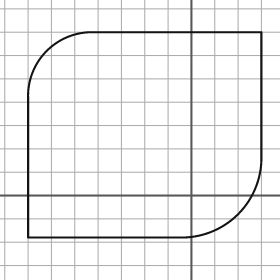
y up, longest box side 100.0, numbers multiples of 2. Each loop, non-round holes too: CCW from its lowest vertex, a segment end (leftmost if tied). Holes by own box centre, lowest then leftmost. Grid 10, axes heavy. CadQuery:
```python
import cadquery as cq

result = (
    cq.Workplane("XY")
    .moveTo(-70.0, -18.0)
    .lineTo(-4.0, -18.0)
    .threePointArc((20.0, -8.0), (30.0, 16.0))
    .lineTo(30.0, 70.0)
    .lineTo(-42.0, 70.0)
    .threePointArc((-62.0, 62.0), (-70.0, 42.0))
    .close()
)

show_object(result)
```